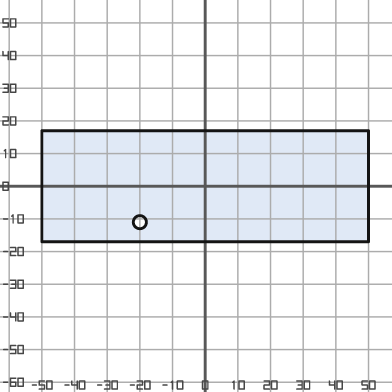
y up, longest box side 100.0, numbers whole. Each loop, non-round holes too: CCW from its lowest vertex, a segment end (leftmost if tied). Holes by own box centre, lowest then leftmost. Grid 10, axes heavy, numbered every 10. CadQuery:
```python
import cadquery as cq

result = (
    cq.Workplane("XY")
    .moveTo(-50.0, -17.0)
    .lineTo(50.0, -17.0)
    .lineTo(50.0, 17.0)
    .lineTo(-50.0, 17.0)
    .close()
    .moveTo(-20.0, -11.0)
    .circle(2.0)
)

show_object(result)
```